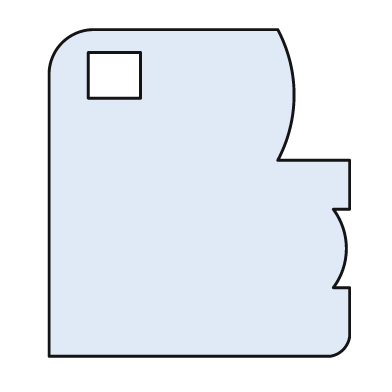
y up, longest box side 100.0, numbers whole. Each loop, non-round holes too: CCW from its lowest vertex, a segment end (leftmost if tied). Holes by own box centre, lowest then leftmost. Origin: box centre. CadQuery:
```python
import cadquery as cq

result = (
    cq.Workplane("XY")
    .moveTo(-46.0, -50.0)
    .lineTo(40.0, -50.0)
    .threePointArc((44.0, -48.0), (46.0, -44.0))
    .lineTo(46.0, -29.0)
    .lineTo(41.0, -29.0)
    .threePointArc((45.0, -17.0), (41.0, -5.0))
    .lineTo(46.0, -5.0)
    .lineTo(46.0, 10.0)
    .lineTo(24.0, 10.0)
    .threePointArc((29.0, 30.0), (24.0, 50.0))
    .lineTo(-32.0, 50.0)
    .threePointArc((-42.0, 46.0), (-46.0, 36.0))
    .close()
    .moveTo(-34.0, 29.0)
    .lineTo(-18.0, 29.0)
    .lineTo(-18.0, 43.0)
    .lineTo(-34.0, 43.0)
    .close()
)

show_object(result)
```